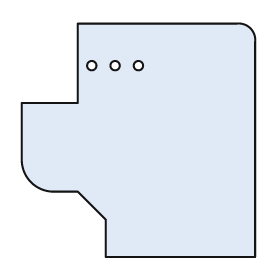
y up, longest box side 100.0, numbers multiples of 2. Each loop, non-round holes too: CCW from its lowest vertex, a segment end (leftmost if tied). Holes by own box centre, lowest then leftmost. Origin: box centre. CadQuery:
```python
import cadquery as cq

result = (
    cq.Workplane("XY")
    .moveTo(-14.0, -50.0)
    .lineTo(50.0, -50.0)
    .lineTo(50.0, 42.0)
    .threePointArc((48.0, 48.0), (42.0, 50.0))
    .lineTo(-26.0, 50.0)
    .lineTo(-26.0, 16.0)
    .lineTo(-50.0, 16.0)
    .lineTo(-50.0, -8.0)
    .threePointArc((-46.0, -18.0), (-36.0, -22.0))
    .lineTo(-26.0, -22.0)
    .lineTo(-14.0, -34.0)
    .close()
    .moveTo(-20.0, 32.0)
    .circle(2.0)
    .moveTo(-10.0, 32.0)
    .circle(2.0)
    .moveTo(0.0, 32.0)
    .circle(2.0)
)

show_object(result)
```